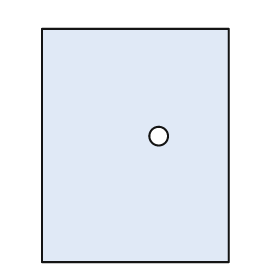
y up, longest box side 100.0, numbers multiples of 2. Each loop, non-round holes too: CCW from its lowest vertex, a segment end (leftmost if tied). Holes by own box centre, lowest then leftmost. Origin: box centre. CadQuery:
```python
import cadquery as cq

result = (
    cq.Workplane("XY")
    .moveTo(-40.0, -50.0)
    .lineTo(40.0, -50.0)
    .lineTo(40.0, 50.0)
    .lineTo(-40.0, 50.0)
    .close()
    .moveTo(10.0, 4.0)
    .circle(4.0)
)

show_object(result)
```